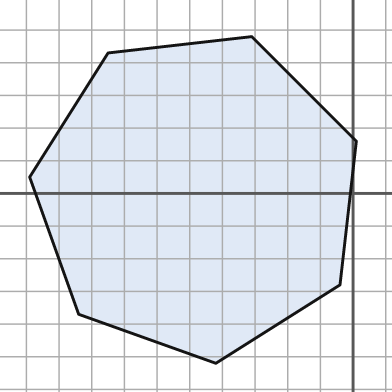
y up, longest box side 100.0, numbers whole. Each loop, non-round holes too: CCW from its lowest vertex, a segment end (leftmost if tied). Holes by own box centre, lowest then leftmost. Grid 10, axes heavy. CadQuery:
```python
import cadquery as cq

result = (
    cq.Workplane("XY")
    .moveTo(-42.0, -52.0)
    .lineTo(-4.0, -28.0)
    .lineTo(1.0, 16.0)
    .lineTo(-31.0, 48.0)
    .lineTo(-75.0, 43.0)
    .lineTo(-99.0, 5.0)
    .lineTo(-84.0, -37.0)
    .close()
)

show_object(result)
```